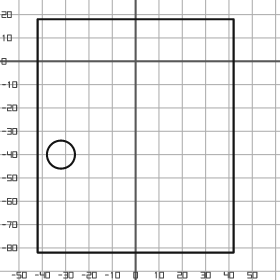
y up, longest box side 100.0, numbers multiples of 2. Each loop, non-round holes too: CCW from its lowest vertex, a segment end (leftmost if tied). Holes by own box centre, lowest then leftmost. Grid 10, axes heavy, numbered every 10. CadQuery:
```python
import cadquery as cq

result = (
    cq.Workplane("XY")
    .moveTo(-42.0, -82.0)
    .lineTo(42.0, -82.0)
    .lineTo(42.0, 18.0)
    .lineTo(-42.0, 18.0)
    .close()
    .moveTo(-32.0, -40.0)
    .circle(6.0)
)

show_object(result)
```